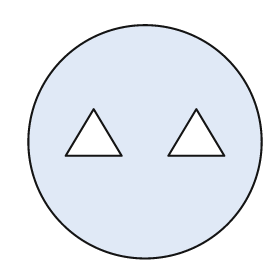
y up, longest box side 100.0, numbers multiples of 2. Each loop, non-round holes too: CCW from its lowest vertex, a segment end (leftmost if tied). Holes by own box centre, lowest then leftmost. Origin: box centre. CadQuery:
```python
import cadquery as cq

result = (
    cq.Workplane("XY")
    .moveTo(0.0, 0.0)
    .circle(50.0)
    .moveTo(-34.0, -6.0)
    .lineTo(-10.0, -6.0)
    .lineTo(-22.0, 14.0)
    .close()
    .moveTo(10.0, -6.0)
    .lineTo(34.0, -6.0)
    .lineTo(22.0, 14.0)
    .close()
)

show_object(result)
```